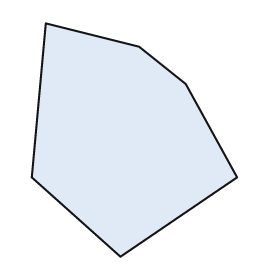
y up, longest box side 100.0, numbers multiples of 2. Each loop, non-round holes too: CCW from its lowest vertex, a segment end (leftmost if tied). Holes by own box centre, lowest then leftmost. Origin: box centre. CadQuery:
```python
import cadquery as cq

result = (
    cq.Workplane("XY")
    .moveTo(-6.0, -50.0)
    .lineTo(44.0, -16.0)
    .lineTo(22.0, 24.0)
    .lineTo(2.0, 40.0)
    .lineTo(-38.0, 50.0)
    .lineTo(-44.0, -16.0)
    .close()
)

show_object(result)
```